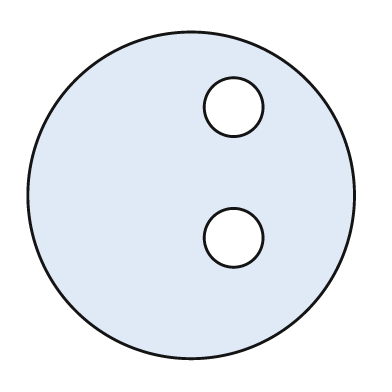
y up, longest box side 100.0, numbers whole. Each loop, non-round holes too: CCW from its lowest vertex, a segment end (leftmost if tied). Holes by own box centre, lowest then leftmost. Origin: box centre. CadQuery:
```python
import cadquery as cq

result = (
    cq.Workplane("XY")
    .moveTo(0.0, 0.0)
    .circle(50.0)
    .moveTo(13.0, -13.0)
    .circle(9.0)
    .moveTo(13.0, 27.0)
    .circle(9.0)
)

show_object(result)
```